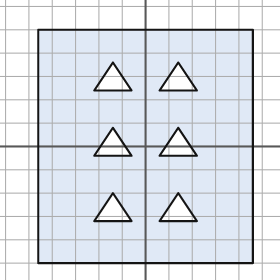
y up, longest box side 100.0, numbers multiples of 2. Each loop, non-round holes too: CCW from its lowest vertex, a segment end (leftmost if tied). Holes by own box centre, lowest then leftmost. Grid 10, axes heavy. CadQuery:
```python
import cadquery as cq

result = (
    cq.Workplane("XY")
    .moveTo(-46.0, -50.0)
    .lineTo(46.0, -50.0)
    .lineTo(46.0, 50.0)
    .lineTo(-46.0, 50.0)
    .close()
    .moveTo(-22.0, -32.0)
    .lineTo(-6.0, -32.0)
    .lineTo(-14.0, -20.0)
    .close()
    .moveTo(6.0, -32.0)
    .lineTo(22.0, -32.0)
    .lineTo(14.0, -20.0)
    .close()
    .moveTo(-22.0, -4.0)
    .lineTo(-6.0, -4.0)
    .lineTo(-14.0, 8.0)
    .close()
    .moveTo(6.0, -4.0)
    .lineTo(22.0, -4.0)
    .lineTo(14.0, 8.0)
    .close()
    .moveTo(-22.0, 24.0)
    .lineTo(-6.0, 24.0)
    .lineTo(-14.0, 36.0)
    .close()
    .moveTo(6.0, 24.0)
    .lineTo(22.0, 24.0)
    .lineTo(14.0, 36.0)
    .close()
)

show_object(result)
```